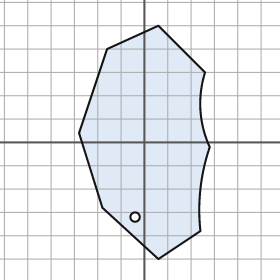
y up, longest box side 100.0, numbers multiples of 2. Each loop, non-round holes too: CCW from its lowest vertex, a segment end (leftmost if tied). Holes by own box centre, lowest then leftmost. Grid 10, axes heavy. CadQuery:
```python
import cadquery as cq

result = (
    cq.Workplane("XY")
    .moveTo(6.0, -50.0)
    .lineTo(24.0, -38.0)
    .threePointArc((24.0, -20.0), (28.0, -2.0))
    .threePointArc((24.0, 14.0), (26.0, 30.0))
    .lineTo(6.0, 50.0)
    .lineTo(-16.0, 40.0)
    .lineTo(-28.0, 4.0)
    .lineTo(-18.0, -28.0)
    .close()
    .moveTo(-4.0, -32.0)
    .circle(2.0)
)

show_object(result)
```